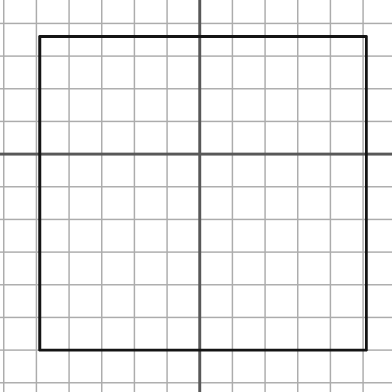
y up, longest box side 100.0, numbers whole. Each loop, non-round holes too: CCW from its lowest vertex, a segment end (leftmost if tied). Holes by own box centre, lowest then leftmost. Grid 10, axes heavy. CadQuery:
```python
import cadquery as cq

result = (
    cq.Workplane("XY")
    .moveTo(-49.0, -60.0)
    .lineTo(51.0, -60.0)
    .lineTo(51.0, 36.0)
    .lineTo(-49.0, 36.0)
    .close()
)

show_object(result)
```